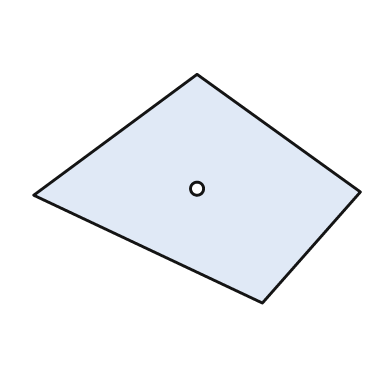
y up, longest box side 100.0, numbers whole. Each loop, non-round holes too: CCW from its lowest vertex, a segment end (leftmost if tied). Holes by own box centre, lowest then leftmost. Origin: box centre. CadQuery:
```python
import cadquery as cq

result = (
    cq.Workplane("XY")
    .moveTo(20.0, -35.0)
    .lineTo(50.0, -1.0)
    .lineTo(0.0, 35.0)
    .lineTo(-50.0, -2.0)
    .close()
    .moveTo(0.0, 0.0)
    .circle(2.0)
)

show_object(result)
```